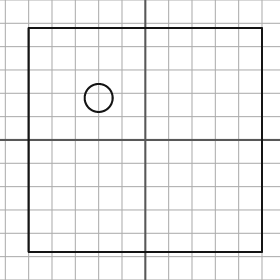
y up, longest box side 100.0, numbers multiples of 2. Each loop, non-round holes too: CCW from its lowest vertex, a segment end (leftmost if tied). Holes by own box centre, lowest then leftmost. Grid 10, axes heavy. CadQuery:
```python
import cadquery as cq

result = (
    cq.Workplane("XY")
    .moveTo(-50.0, -48.0)
    .lineTo(50.0, -48.0)
    .lineTo(50.0, 48.0)
    .lineTo(-50.0, 48.0)
    .close()
    .moveTo(-20.0, 18.0)
    .circle(6.0)
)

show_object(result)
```